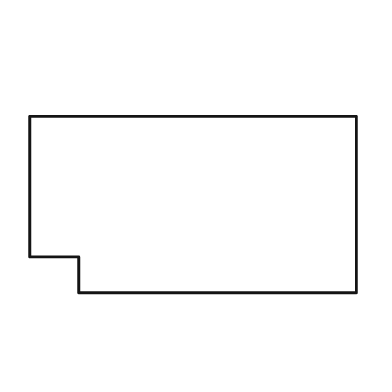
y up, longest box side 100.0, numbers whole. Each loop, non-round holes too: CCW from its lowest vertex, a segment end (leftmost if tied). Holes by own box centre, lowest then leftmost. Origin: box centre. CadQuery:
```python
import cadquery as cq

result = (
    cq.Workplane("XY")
    .moveTo(-35.0, -27.0)
    .lineTo(50.0, -27.0)
    .lineTo(50.0, 27.0)
    .lineTo(-50.0, 27.0)
    .lineTo(-50.0, -16.0)
    .lineTo(-35.0, -16.0)
    .close()
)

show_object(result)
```